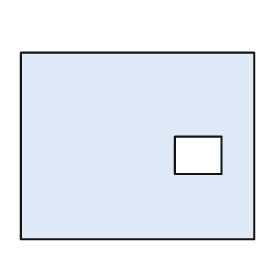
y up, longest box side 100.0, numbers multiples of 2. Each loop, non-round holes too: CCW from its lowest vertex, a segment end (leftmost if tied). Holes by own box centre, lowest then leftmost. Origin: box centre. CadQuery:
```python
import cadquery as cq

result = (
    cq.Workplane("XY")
    .moveTo(-50.0, -40.0)
    .lineTo(50.0, -40.0)
    .lineTo(50.0, 40.0)
    .lineTo(-50.0, 40.0)
    .close()
    .moveTo(16.0, -12.0)
    .lineTo(36.0, -12.0)
    .lineTo(36.0, 4.0)
    .lineTo(16.0, 4.0)
    .close()
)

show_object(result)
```